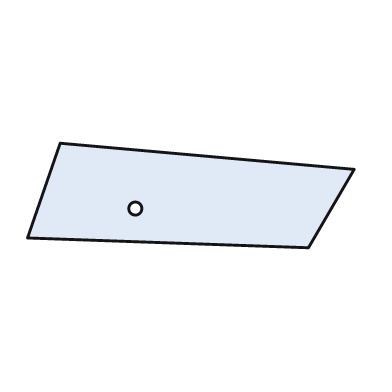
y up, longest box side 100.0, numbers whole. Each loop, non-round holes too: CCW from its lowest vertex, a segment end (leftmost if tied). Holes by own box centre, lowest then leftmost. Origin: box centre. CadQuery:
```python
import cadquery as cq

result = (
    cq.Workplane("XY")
    .moveTo(36.0, -16.0)
    .lineTo(50.0, 8.0)
    .lineTo(-40.0, 16.0)
    .lineTo(-50.0, -13.0)
    .close()
    .moveTo(-17.0, -4.0)
    .circle(2.0)
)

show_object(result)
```